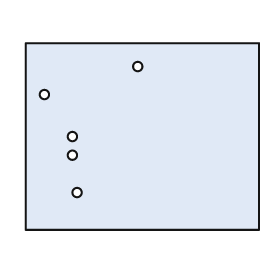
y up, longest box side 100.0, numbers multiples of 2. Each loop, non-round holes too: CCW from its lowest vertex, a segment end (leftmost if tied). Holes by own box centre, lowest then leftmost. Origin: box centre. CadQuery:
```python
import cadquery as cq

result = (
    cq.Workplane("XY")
    .moveTo(-50.0, -40.0)
    .lineTo(50.0, -40.0)
    .lineTo(50.0, 40.0)
    .lineTo(-50.0, 40.0)
    .close()
    .moveTo(-28.0, -24.0)
    .circle(2.0)
    .moveTo(-30.0, -8.0)
    .circle(2.0)
    .moveTo(-30.0, 0.0)
    .circle(2.0)
    .moveTo(-42.0, 18.0)
    .circle(2.0)
    .moveTo(-2.0, 30.0)
    .circle(2.0)
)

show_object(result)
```